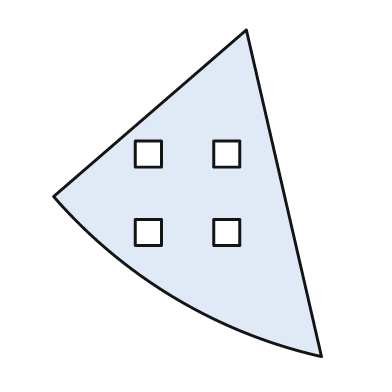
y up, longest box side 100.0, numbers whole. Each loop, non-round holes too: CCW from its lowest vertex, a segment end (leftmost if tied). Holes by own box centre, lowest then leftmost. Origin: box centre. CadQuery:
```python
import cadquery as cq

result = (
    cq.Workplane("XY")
    .moveTo(41.0, -50.0)
    .lineTo(18.0, 50.0)
    .lineTo(-41.0, -1.0)
    .threePointArc((-4.0, -32.0), (41.0, -50.0))
    .close()
    .moveTo(-16.0, -16.0)
    .lineTo(-8.0, -16.0)
    .lineTo(-8.0, -8.0)
    .lineTo(-16.0, -8.0)
    .close()
    .moveTo(8.0, -16.0)
    .lineTo(16.0, -16.0)
    .lineTo(16.0, -8.0)
    .lineTo(8.0, -8.0)
    .close()
    .moveTo(-16.0, 8.0)
    .lineTo(-8.0, 8.0)
    .lineTo(-8.0, 16.0)
    .lineTo(-16.0, 16.0)
    .close()
    .moveTo(8.0, 8.0)
    .lineTo(16.0, 8.0)
    .lineTo(16.0, 16.0)
    .lineTo(8.0, 16.0)
    .close()
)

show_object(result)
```